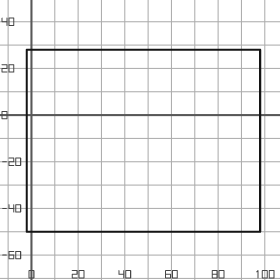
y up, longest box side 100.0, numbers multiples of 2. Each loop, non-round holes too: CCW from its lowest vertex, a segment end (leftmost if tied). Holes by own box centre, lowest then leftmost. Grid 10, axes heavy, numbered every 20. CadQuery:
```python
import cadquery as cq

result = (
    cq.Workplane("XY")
    .moveTo(-2.0, -50.0)
    .lineTo(98.0, -50.0)
    .lineTo(98.0, 28.0)
    .lineTo(-2.0, 28.0)
    .close()
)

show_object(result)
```